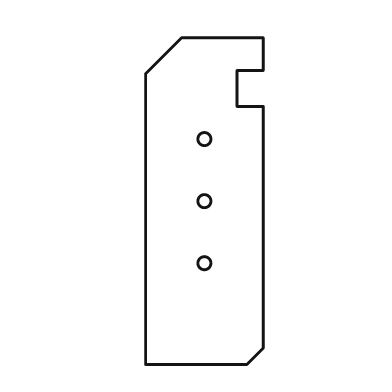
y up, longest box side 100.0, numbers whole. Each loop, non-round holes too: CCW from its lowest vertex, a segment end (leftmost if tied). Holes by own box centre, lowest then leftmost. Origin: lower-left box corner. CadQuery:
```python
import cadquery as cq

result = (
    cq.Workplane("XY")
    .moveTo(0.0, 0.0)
    .lineTo(31.0, 0.0)
    .lineTo(36.0, 5.0)
    .lineTo(36.0, 79.0)
    .lineTo(28.0, 79.0)
    .lineTo(28.0, 90.0)
    .lineTo(36.0, 90.0)
    .lineTo(36.0, 100.0)
    .lineTo(11.0, 100.0)
    .lineTo(0.0, 89.0)
    .close()
    .moveTo(18.0, 31.0)
    .circle(2.0)
    .moveTo(18.0, 50.0)
    .circle(2.0)
    .moveTo(18.0, 69.0)
    .circle(2.0)
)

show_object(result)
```